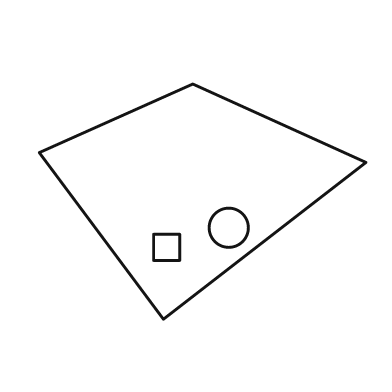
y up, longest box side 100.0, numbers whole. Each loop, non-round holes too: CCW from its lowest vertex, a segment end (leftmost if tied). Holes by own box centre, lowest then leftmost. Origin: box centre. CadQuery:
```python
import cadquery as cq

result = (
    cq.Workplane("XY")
    .moveTo(-12.0, -36.0)
    .lineTo(50.0, 12.0)
    .lineTo(-3.0, 36.0)
    .lineTo(-50.0, 15.0)
    .close()
    .moveTo(-15.0, -18.0)
    .lineTo(-7.0, -18.0)
    .lineTo(-7.0, -10.0)
    .lineTo(-15.0, -10.0)
    .close()
    .moveTo(8.0, -8.0)
    .circle(6.0)
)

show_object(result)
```